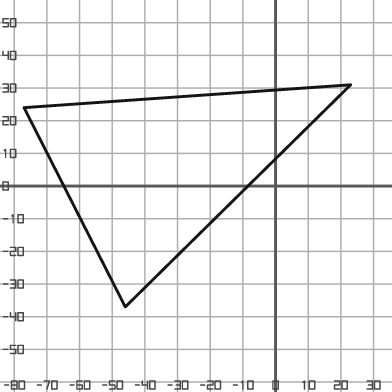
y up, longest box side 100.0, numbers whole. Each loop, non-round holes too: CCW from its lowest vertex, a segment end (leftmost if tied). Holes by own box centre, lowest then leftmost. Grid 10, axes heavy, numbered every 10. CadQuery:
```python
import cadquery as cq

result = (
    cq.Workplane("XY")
    .moveTo(-46.0, -37.0)
    .lineTo(23.0, 31.0)
    .lineTo(-77.0, 24.0)
    .close()
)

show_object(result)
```